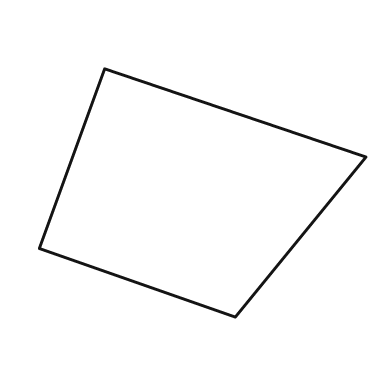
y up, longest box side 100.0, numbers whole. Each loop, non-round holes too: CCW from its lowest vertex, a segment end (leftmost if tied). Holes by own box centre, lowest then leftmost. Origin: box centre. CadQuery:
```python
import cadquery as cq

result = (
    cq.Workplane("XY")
    .moveTo(10.0, -38.0)
    .lineTo(50.0, 11.0)
    .lineTo(-30.0, 38.0)
    .lineTo(-50.0, -17.0)
    .close()
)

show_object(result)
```